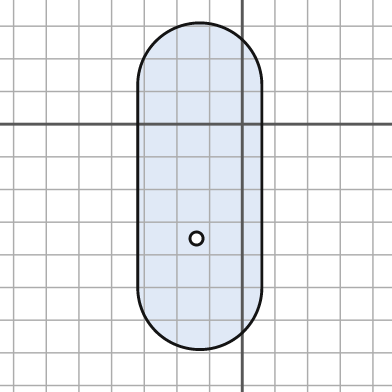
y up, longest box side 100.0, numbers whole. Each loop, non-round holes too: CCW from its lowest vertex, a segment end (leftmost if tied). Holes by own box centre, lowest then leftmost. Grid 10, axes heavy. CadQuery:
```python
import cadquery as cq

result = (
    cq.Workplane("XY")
    .moveTo(-32.0, -50.0)
    .threePointArc((-13.0, -69.0), (6.0, -50.0))
    .lineTo(6.0, 12.0)
    .threePointArc((-13.0, 31.0), (-32.0, 12.0))
    .close()
    .moveTo(-14.0, -35.0)
    .circle(2.0)
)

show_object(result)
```